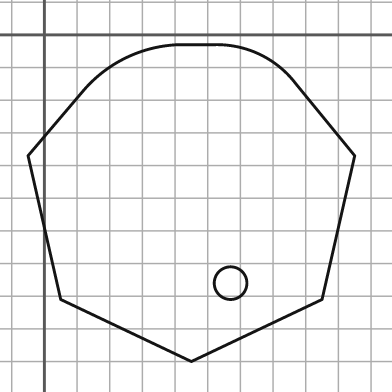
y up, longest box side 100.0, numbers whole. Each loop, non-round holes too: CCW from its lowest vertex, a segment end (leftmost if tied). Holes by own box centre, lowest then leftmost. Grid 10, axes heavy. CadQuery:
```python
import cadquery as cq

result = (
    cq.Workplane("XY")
    .moveTo(45.0, -100.0)
    .lineTo(85.0, -81.0)
    .lineTo(95.0, -37.0)
    .lineTo(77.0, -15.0)
    .threePointArc((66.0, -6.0), (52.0, -3.0))
    .lineTo(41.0, -3.0)
    .threePointArc((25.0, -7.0), (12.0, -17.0))
    .lineTo(-5.0, -37.0)
    .lineTo(5.0, -81.0)
    .close()
    .moveTo(57.0, -76.0)
    .circle(5.0)
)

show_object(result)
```